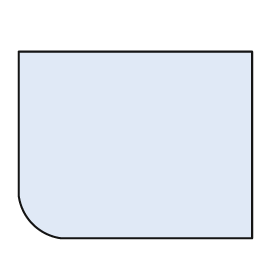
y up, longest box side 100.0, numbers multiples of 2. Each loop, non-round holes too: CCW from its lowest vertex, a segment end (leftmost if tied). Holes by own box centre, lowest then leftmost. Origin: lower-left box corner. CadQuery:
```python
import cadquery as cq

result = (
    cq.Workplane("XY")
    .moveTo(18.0, 0.0)
    .lineTo(100.0, 0.0)
    .lineTo(100.0, 80.0)
    .lineTo(0.0, 80.0)
    .lineTo(0.0, 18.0)
    .threePointArc((6.0, 6.0), (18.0, 0.0))
    .close()
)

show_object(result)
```